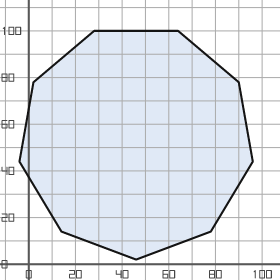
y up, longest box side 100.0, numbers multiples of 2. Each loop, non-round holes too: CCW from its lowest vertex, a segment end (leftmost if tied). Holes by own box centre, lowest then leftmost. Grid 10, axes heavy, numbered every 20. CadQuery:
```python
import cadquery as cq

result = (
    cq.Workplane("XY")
    .moveTo(46.0, 2.0)
    .lineTo(78.0, 14.0)
    .lineTo(96.0, 44.0)
    .lineTo(90.0, 78.0)
    .lineTo(64.0, 100.0)
    .lineTo(28.0, 100.0)
    .lineTo(2.0, 78.0)
    .lineTo(-4.0, 44.0)
    .lineTo(14.0, 14.0)
    .close()
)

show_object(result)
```